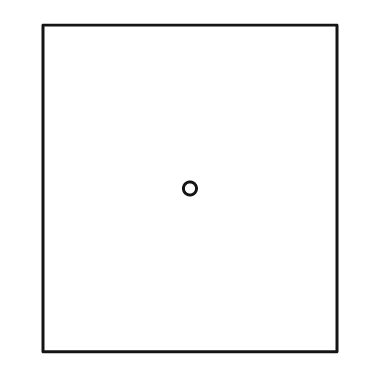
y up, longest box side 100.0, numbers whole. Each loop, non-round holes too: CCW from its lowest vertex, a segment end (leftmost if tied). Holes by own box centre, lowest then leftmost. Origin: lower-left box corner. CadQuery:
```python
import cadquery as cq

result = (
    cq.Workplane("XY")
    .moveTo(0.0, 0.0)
    .lineTo(90.0, 0.0)
    .lineTo(90.0, 100.0)
    .lineTo(0.0, 100.0)
    .close()
    .moveTo(45.0, 50.0)
    .circle(2.0)
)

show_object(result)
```